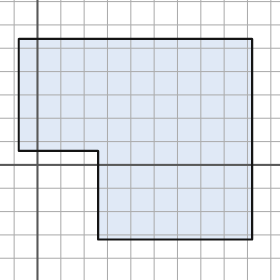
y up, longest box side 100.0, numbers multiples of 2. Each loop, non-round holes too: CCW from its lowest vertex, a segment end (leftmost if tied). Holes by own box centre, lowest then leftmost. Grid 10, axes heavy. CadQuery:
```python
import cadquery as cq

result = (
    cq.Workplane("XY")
    .moveTo(26.0, -32.0)
    .lineTo(92.0, -32.0)
    .lineTo(92.0, 54.0)
    .lineTo(-8.0, 54.0)
    .lineTo(-8.0, 6.0)
    .lineTo(26.0, 6.0)
    .close()
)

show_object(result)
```